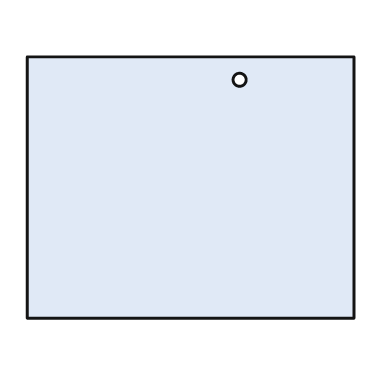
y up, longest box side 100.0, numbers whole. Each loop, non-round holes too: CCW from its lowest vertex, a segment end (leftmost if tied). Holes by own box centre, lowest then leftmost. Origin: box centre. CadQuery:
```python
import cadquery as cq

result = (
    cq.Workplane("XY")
    .moveTo(-50.0, -40.0)
    .lineTo(50.0, -40.0)
    .lineTo(50.0, 40.0)
    .lineTo(-50.0, 40.0)
    .close()
    .moveTo(15.0, 33.0)
    .circle(2.0)
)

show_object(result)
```